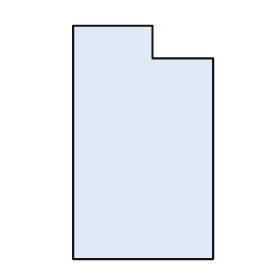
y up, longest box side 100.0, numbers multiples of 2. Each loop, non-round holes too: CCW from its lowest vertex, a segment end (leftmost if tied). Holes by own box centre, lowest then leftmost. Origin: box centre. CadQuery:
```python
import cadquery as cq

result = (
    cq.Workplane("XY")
    .moveTo(-30.0, -50.0)
    .lineTo(30.0, -50.0)
    .lineTo(30.0, 36.0)
    .lineTo(4.0, 36.0)
    .lineTo(4.0, 50.0)
    .lineTo(-30.0, 50.0)
    .close()
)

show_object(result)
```